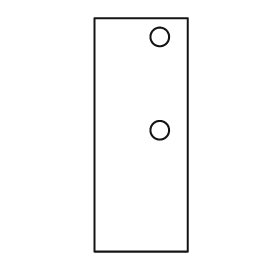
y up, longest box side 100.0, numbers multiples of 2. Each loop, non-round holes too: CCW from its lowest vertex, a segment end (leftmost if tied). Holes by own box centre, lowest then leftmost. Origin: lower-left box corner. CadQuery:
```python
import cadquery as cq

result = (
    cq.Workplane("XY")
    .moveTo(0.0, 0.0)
    .lineTo(40.0, 0.0)
    .lineTo(40.0, 100.0)
    .lineTo(0.0, 100.0)
    .close()
    .moveTo(28.0, 52.0)
    .circle(4.0)
    .moveTo(28.0, 92.0)
    .circle(4.0)
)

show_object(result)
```